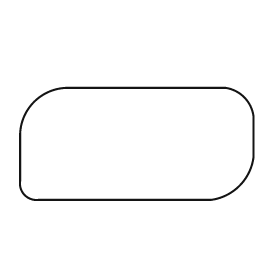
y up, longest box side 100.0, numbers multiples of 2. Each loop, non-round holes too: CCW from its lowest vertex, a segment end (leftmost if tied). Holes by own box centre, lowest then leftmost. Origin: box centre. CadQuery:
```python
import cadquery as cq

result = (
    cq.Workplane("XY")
    .moveTo(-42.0, -24.0)
    .lineTo(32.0, -24.0)
    .threePointArc((44.0, -18.0), (50.0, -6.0))
    .lineTo(50.0, 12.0)
    .threePointArc((46.0, 20.0), (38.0, 24.0))
    .lineTo(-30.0, 24.0)
    .threePointArc((-44.0, 18.0), (-50.0, 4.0))
    .lineTo(-50.0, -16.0)
    .threePointArc((-48.0, -22.0), (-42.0, -24.0))
    .close()
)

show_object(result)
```